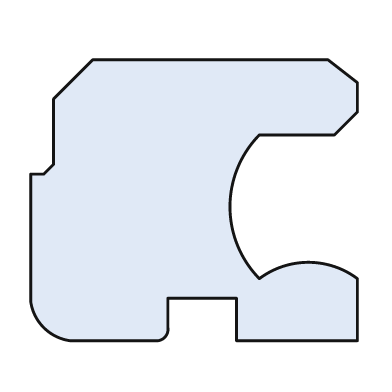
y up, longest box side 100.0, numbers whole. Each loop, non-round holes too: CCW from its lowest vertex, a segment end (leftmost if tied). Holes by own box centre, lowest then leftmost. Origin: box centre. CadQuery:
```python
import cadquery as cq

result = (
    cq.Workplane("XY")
    .moveTo(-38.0, -43.0)
    .lineTo(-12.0, -43.0)
    .threePointArc((-9.0, -42.0), (-8.0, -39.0))
    .lineTo(-8.0, -30.0)
    .lineTo(13.0, -30.0)
    .lineTo(13.0, -43.0)
    .lineTo(50.0, -43.0)
    .lineTo(50.0, -24.0)
    .threePointArc((35.0, -19.0), (20.0, -24.0))
    .threePointArc((11.0, -2.0), (20.0, 20.0))
    .lineTo(43.0, 20.0)
    .lineTo(50.0, 27.0)
    .lineTo(50.0, 36.0)
    .lineTo(41.0, 43.0)
    .lineTo(-31.0, 43.0)
    .lineTo(-43.0, 31.0)
    .lineTo(-43.0, 11.0)
    .lineTo(-46.0, 8.0)
    .lineTo(-50.0, 8.0)
    .lineTo(-50.0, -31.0)
    .threePointArc((-46.0, -39.0), (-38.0, -43.0))
    .close()
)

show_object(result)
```